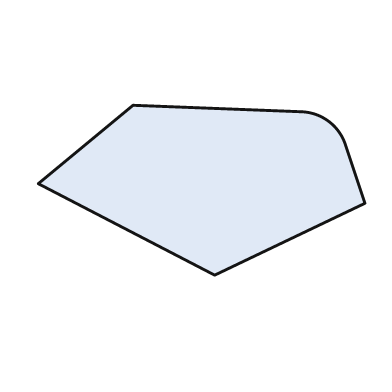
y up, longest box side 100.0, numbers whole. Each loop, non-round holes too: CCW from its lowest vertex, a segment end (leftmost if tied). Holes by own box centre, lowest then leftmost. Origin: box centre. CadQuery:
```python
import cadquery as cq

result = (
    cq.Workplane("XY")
    .moveTo(4.0, -26.0)
    .lineTo(50.0, -4.0)
    .lineTo(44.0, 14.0)
    .threePointArc((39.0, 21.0), (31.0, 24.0))
    .lineTo(-21.0, 26.0)
    .lineTo(-50.0, 2.0)
    .close()
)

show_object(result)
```